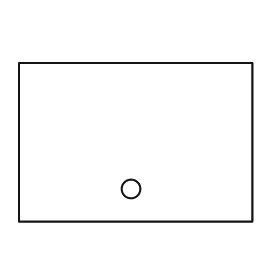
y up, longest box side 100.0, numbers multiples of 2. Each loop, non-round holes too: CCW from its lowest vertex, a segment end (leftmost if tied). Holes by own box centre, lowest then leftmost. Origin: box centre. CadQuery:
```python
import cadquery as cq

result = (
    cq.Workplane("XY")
    .moveTo(-50.0, -34.0)
    .lineTo(50.0, -34.0)
    .lineTo(50.0, 34.0)
    .lineTo(-50.0, 34.0)
    .close()
    .moveTo(-2.0, -20.0)
    .circle(4.0)
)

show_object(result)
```